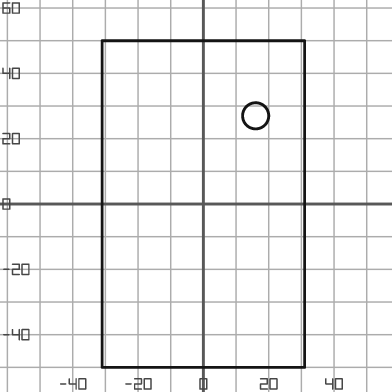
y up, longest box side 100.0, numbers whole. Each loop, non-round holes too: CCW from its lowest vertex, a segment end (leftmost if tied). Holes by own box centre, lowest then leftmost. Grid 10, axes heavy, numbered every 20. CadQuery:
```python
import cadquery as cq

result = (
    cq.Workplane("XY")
    .moveTo(-31.0, -50.0)
    .lineTo(31.0, -50.0)
    .lineTo(31.0, 50.0)
    .lineTo(-31.0, 50.0)
    .close()
    .moveTo(16.0, 27.0)
    .circle(4.0)
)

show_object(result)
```